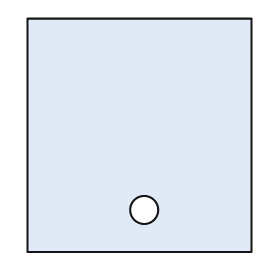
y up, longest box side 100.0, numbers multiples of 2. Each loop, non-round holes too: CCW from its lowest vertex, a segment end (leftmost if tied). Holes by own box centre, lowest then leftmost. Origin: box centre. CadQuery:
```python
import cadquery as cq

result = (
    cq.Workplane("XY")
    .moveTo(-48.0, -50.0)
    .lineTo(48.0, -50.0)
    .lineTo(48.0, 50.0)
    .lineTo(-48.0, 50.0)
    .close()
    .moveTo(2.0, -32.0)
    .circle(6.0)
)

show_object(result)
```